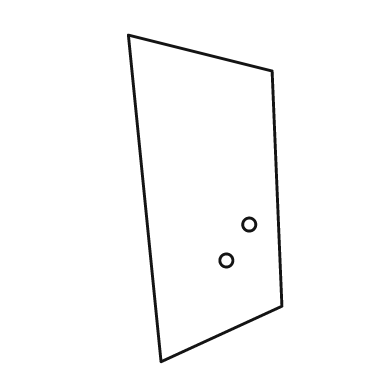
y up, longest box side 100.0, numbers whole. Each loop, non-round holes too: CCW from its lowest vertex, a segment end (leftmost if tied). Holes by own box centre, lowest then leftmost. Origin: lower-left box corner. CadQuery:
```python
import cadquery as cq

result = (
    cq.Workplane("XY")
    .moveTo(10.0, 0.0)
    .lineTo(47.0, 17.0)
    .lineTo(44.0, 89.0)
    .lineTo(0.0, 100.0)
    .close()
    .moveTo(30.0, 31.0)
    .circle(2.0)
    .moveTo(37.0, 42.0)
    .circle(2.0)
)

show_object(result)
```